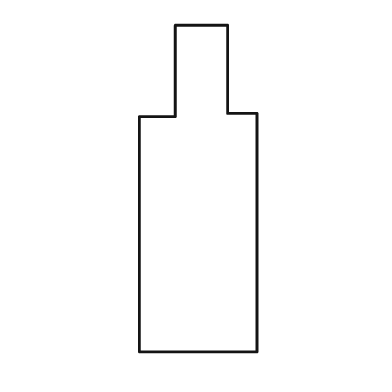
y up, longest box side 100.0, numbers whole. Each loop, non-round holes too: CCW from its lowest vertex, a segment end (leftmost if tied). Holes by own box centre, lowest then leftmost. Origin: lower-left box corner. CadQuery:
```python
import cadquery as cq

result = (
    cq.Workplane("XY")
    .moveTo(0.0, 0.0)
    .lineTo(36.0, 0.0)
    .lineTo(36.0, 73.0)
    .lineTo(27.0, 73.0)
    .lineTo(27.0, 100.0)
    .lineTo(11.0, 100.0)
    .lineTo(11.0, 72.0)
    .lineTo(0.0, 72.0)
    .close()
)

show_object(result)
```